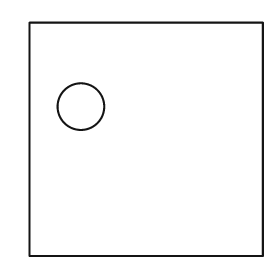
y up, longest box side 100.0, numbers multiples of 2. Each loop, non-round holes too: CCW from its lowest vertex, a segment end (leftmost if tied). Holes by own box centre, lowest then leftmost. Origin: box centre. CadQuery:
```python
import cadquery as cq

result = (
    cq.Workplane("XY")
    .moveTo(-50.0, -50.0)
    .lineTo(50.0, -50.0)
    .lineTo(50.0, 50.0)
    .lineTo(-50.0, 50.0)
    .close()
    .moveTo(-28.0, 14.0)
    .circle(10.0)
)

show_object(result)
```